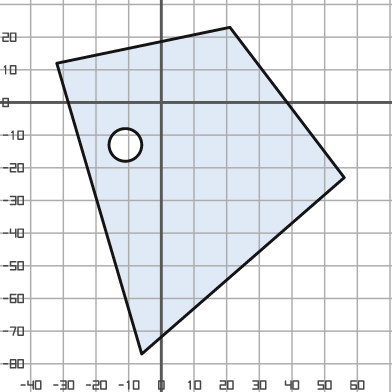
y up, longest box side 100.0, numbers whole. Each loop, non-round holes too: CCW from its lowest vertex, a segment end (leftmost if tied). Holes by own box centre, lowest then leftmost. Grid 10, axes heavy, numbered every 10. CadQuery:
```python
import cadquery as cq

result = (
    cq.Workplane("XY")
    .moveTo(-6.0, -77.0)
    .lineTo(56.0, -23.0)
    .lineTo(21.0, 23.0)
    .lineTo(-32.0, 12.0)
    .close()
    .moveTo(-11.0, -13.0)
    .circle(5.0)
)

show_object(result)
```